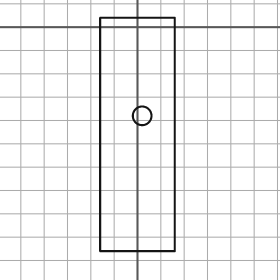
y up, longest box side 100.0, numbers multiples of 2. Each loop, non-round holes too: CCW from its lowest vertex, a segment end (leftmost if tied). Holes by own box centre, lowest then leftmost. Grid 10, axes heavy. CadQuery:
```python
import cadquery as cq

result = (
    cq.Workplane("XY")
    .moveTo(-16.0, -96.0)
    .lineTo(16.0, -96.0)
    .lineTo(16.0, 4.0)
    .lineTo(-16.0, 4.0)
    .close()
    .moveTo(2.0, -38.0)
    .circle(4.0)
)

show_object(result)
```